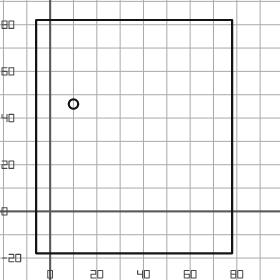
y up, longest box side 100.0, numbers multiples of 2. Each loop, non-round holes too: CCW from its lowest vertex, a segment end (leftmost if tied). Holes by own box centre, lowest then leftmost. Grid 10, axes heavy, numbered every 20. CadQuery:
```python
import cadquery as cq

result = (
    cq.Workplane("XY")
    .moveTo(-6.0, -18.0)
    .lineTo(78.0, -18.0)
    .lineTo(78.0, 82.0)
    .lineTo(-6.0, 82.0)
    .close()
    .moveTo(10.0, 46.0)
    .circle(2.0)
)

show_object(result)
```